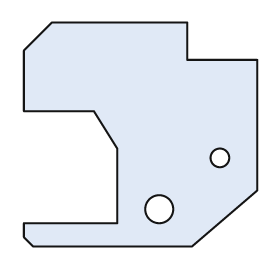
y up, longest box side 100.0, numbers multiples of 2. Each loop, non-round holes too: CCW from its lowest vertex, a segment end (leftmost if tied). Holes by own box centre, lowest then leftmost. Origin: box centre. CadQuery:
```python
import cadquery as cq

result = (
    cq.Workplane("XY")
    .moveTo(-46.0, -48.0)
    .lineTo(22.0, -48.0)
    .lineTo(50.0, -24.0)
    .lineTo(50.0, 32.0)
    .lineTo(20.0, 32.0)
    .lineTo(20.0, 48.0)
    .lineTo(-38.0, 48.0)
    .lineTo(-50.0, 36.0)
    .lineTo(-50.0, 10.0)
    .lineTo(-20.0, 10.0)
    .lineTo(-10.0, -6.0)
    .lineTo(-10.0, -38.0)
    .lineTo(-50.0, -38.0)
    .lineTo(-50.0, -44.0)
    .close()
    .moveTo(8.0, -32.0)
    .circle(6.0)
    .moveTo(34.0, -10.0)
    .circle(4.0)
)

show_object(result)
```